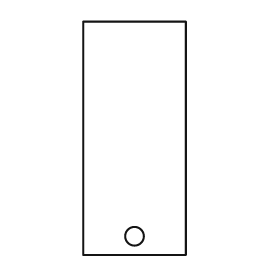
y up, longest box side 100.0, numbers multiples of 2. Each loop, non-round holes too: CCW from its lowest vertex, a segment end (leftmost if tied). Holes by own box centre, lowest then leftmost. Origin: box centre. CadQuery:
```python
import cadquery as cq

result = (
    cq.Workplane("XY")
    .moveTo(-22.0, -50.0)
    .lineTo(22.0, -50.0)
    .lineTo(22.0, 50.0)
    .lineTo(-22.0, 50.0)
    .close()
    .moveTo(0.0, -42.0)
    .circle(4.0)
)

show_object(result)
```